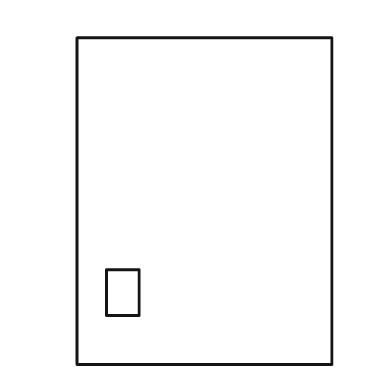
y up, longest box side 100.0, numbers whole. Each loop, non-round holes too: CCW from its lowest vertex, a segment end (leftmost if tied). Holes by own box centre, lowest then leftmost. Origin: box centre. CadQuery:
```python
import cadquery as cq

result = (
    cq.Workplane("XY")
    .moveTo(-39.0, -50.0)
    .lineTo(39.0, -50.0)
    .lineTo(39.0, 50.0)
    .lineTo(-39.0, 50.0)
    .close()
    .moveTo(-30.0, -35.0)
    .lineTo(-20.0, -35.0)
    .lineTo(-20.0, -21.0)
    .lineTo(-30.0, -21.0)
    .close()
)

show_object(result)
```